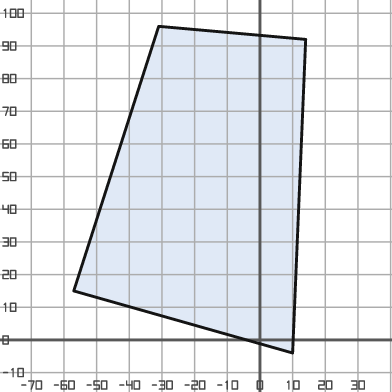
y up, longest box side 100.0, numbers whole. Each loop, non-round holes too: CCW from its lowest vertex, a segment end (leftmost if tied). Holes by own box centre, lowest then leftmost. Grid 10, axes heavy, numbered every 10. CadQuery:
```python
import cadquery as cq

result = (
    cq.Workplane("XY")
    .moveTo(10.0, -4.0)
    .lineTo(14.0, 92.0)
    .lineTo(-31.0, 96.0)
    .lineTo(-57.0, 15.0)
    .close()
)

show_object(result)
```